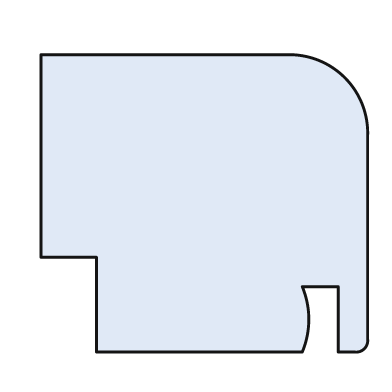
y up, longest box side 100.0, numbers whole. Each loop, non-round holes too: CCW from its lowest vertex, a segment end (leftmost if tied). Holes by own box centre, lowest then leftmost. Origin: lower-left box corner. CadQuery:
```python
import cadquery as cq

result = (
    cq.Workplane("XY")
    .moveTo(17.0, 0.0)
    .lineTo(80.0, 0.0)
    .threePointArc((82.0, 10.0), (80.0, 20.0))
    .lineTo(91.0, 20.0)
    .lineTo(91.0, 0.0)
    .lineTo(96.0, 0.0)
    .threePointArc((99.0, 1.0), (100.0, 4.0))
    .lineTo(100.0, 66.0)
    .threePointArc((93.0, 84.0), (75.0, 91.0))
    .lineTo(0.0, 91.0)
    .lineTo(0.0, 29.0)
    .lineTo(17.0, 29.0)
    .close()
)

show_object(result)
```